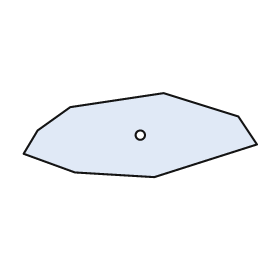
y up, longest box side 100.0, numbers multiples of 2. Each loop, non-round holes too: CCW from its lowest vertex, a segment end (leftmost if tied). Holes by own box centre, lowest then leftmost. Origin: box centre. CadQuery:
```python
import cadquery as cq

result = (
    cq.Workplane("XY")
    .moveTo(6.0, -18.0)
    .lineTo(50.0, -4.0)
    .lineTo(42.0, 8.0)
    .lineTo(10.0, 18.0)
    .lineTo(-30.0, 12.0)
    .lineTo(-44.0, 2.0)
    .lineTo(-50.0, -8.0)
    .lineTo(-28.0, -16.0)
    .close()
    .moveTo(0.0, 0.0)
    .circle(2.0)
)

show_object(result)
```